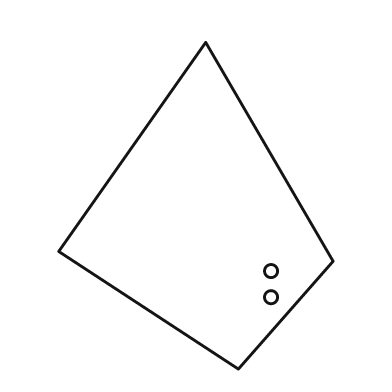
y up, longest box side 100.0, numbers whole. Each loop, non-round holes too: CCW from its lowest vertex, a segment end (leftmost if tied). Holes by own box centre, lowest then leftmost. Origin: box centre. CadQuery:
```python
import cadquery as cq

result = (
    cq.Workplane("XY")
    .moveTo(13.0, -50.0)
    .lineTo(42.0, -17.0)
    .lineTo(3.0, 50.0)
    .lineTo(-42.0, -14.0)
    .close()
    .moveTo(23.0, -28.0)
    .circle(2.0)
    .moveTo(23.0, -20.0)
    .circle(2.0)
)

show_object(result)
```